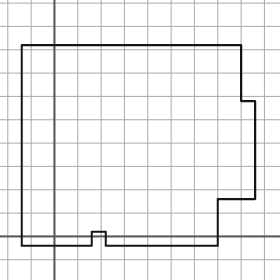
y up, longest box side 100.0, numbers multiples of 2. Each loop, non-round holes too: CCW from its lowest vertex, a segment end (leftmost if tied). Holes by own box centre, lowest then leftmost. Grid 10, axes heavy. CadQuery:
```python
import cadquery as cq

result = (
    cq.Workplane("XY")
    .moveTo(-14.0, -4.0)
    .lineTo(16.0, -4.0)
    .lineTo(16.0, 2.0)
    .lineTo(22.0, 2.0)
    .lineTo(22.0, -4.0)
    .lineTo(70.0, -4.0)
    .lineTo(70.0, 16.0)
    .lineTo(86.0, 16.0)
    .lineTo(86.0, 58.0)
    .lineTo(80.0, 58.0)
    .lineTo(80.0, 82.0)
    .lineTo(-14.0, 82.0)
    .close()
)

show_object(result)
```